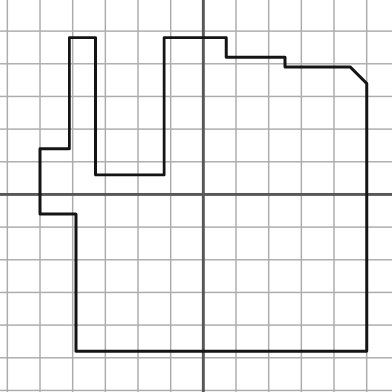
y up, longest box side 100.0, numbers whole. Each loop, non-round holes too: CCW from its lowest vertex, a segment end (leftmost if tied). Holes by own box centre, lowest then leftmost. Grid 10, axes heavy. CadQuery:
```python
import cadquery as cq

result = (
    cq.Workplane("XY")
    .moveTo(-39.0, -48.0)
    .lineTo(50.0, -48.0)
    .lineTo(50.0, 34.0)
    .lineTo(45.0, 39.0)
    .lineTo(25.0, 39.0)
    .lineTo(25.0, 42.0)
    .lineTo(7.0, 42.0)
    .lineTo(7.0, 48.0)
    .lineTo(-12.0, 48.0)
    .lineTo(-12.0, 6.0)
    .lineTo(-33.0, 6.0)
    .lineTo(-33.0, 48.0)
    .lineTo(-41.0, 48.0)
    .lineTo(-41.0, 14.0)
    .lineTo(-50.0, 14.0)
    .lineTo(-50.0, -6.0)
    .lineTo(-39.0, -6.0)
    .close()
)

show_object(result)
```